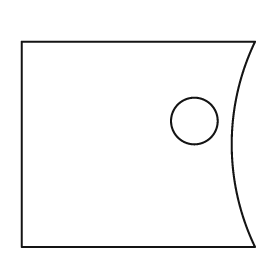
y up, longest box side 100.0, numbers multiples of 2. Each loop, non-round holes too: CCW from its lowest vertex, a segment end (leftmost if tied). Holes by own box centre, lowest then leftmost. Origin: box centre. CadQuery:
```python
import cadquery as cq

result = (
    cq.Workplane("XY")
    .moveTo(-50.0, -44.0)
    .lineTo(50.0, -44.0)
    .threePointArc((40.0, 0.0), (50.0, 44.0))
    .lineTo(-50.0, 44.0)
    .close()
    .moveTo(24.0, 10.0)
    .circle(10.0)
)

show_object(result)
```